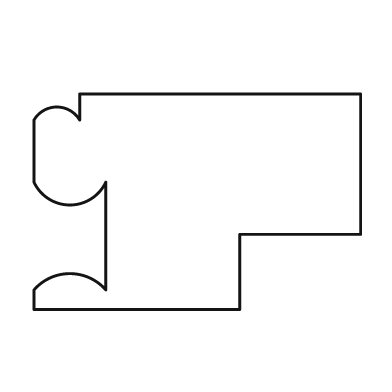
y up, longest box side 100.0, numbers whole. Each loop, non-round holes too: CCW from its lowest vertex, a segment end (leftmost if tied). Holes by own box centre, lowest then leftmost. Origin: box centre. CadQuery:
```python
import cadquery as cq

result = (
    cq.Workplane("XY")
    .moveTo(-50.0, -33.0)
    .lineTo(13.0, -33.0)
    .lineTo(13.0, -10.0)
    .lineTo(50.0, -10.0)
    .lineTo(50.0, 33.0)
    .lineTo(-36.0, 33.0)
    .lineTo(-36.0, 25.0)
    .threePointArc((-43.0, 29.0), (-50.0, 25.0))
    .lineTo(-50.0, 6.0)
    .threePointArc((-39.0, -1.0), (-28.0, 6.0))
    .lineTo(-28.0, -27.0)
    .threePointArc((-39.0, -22.0), (-50.0, -27.0))
    .close()
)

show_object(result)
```